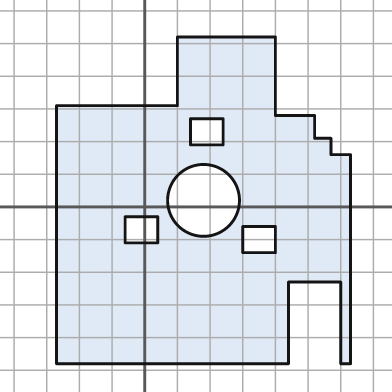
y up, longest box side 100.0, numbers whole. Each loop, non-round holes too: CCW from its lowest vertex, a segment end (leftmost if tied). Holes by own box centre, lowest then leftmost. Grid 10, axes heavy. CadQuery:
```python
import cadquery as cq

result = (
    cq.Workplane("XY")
    .moveTo(-27.0, -48.0)
    .lineTo(44.0, -48.0)
    .lineTo(44.0, -23.0)
    .lineTo(60.0, -23.0)
    .lineTo(60.0, -48.0)
    .lineTo(63.0, -48.0)
    .lineTo(63.0, 16.0)
    .lineTo(57.0, 16.0)
    .lineTo(57.0, 21.0)
    .lineTo(52.0, 21.0)
    .lineTo(52.0, 28.0)
    .lineTo(40.0, 28.0)
    .lineTo(40.0, 52.0)
    .lineTo(10.0, 52.0)
    .lineTo(10.0, 31.0)
    .lineTo(-27.0, 31.0)
    .close()
    .moveTo(30.0, -14.0)
    .lineTo(40.0, -14.0)
    .lineTo(40.0, -6.0)
    .lineTo(30.0, -6.0)
    .close()
    .moveTo(-6.0, -11.0)
    .lineTo(4.0, -11.0)
    .lineTo(4.0, -3.0)
    .lineTo(-6.0, -3.0)
    .close()
    .moveTo(18.0, 2.0)
    .circle(11.0)
    .moveTo(14.0, 19.0)
    .lineTo(24.0, 19.0)
    .lineTo(24.0, 27.0)
    .lineTo(14.0, 27.0)
    .close()
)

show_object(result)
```